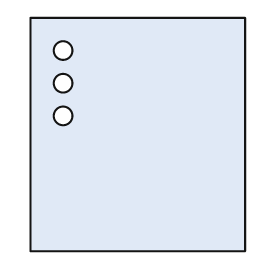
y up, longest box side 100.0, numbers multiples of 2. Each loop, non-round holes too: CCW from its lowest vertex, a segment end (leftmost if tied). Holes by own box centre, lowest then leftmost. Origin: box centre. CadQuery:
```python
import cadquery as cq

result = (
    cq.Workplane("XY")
    .moveTo(-46.0, -50.0)
    .lineTo(46.0, -50.0)
    .lineTo(46.0, 50.0)
    .lineTo(-46.0, 50.0)
    .close()
    .moveTo(-32.0, 8.0)
    .circle(4.0)
    .moveTo(-32.0, 22.0)
    .circle(4.0)
    .moveTo(-32.0, 36.0)
    .circle(4.0)
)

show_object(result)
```